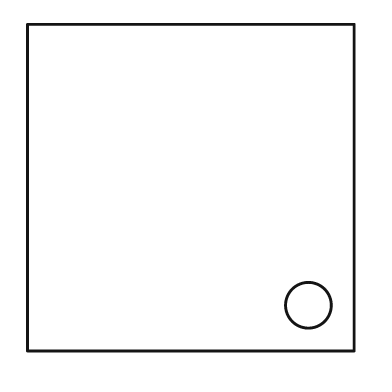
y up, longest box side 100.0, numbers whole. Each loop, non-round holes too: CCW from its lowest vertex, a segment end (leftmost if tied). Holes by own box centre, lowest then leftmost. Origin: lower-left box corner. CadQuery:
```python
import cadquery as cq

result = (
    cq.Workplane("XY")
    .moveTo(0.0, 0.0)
    .lineTo(100.0, 0.0)
    .lineTo(100.0, 100.0)
    .lineTo(0.0, 100.0)
    .close()
    .moveTo(86.0, 14.0)
    .circle(7.0)
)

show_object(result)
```